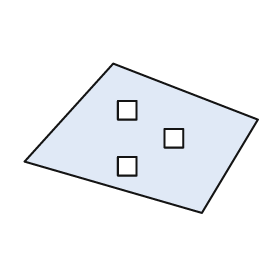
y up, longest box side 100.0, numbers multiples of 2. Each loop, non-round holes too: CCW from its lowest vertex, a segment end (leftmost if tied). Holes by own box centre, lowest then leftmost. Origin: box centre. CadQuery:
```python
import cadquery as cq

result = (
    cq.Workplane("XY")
    .moveTo(26.0, -32.0)
    .lineTo(50.0, 8.0)
    .lineTo(-12.0, 32.0)
    .lineTo(-50.0, -10.0)
    .close()
    .moveTo(-10.0, -16.0)
    .lineTo(-2.0, -16.0)
    .lineTo(-2.0, -8.0)
    .lineTo(-10.0, -8.0)
    .close()
    .moveTo(10.0, -4.0)
    .lineTo(18.0, -4.0)
    .lineTo(18.0, 4.0)
    .lineTo(10.0, 4.0)
    .close()
    .moveTo(-10.0, 8.0)
    .lineTo(-2.0, 8.0)
    .lineTo(-2.0, 16.0)
    .lineTo(-10.0, 16.0)
    .close()
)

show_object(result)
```